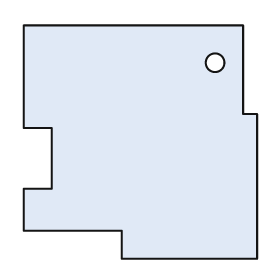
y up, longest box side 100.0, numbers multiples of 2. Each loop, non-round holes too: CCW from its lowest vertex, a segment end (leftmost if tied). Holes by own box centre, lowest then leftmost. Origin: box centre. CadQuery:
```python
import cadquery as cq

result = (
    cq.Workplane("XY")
    .moveTo(-8.0, -50.0)
    .lineTo(50.0, -50.0)
    .lineTo(50.0, 12.0)
    .lineTo(44.0, 12.0)
    .lineTo(44.0, 50.0)
    .lineTo(-50.0, 50.0)
    .lineTo(-50.0, 6.0)
    .lineTo(-38.0, 6.0)
    .lineTo(-38.0, -20.0)
    .lineTo(-50.0, -20.0)
    .lineTo(-50.0, -38.0)
    .lineTo(-8.0, -38.0)
    .close()
    .moveTo(32.0, 34.0)
    .circle(4.0)
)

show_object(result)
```